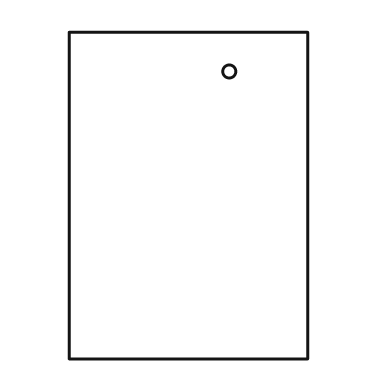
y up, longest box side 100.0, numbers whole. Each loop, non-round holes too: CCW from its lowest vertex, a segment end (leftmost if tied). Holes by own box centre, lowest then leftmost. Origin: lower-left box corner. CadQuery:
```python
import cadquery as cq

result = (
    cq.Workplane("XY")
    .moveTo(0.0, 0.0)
    .lineTo(73.0, 0.0)
    .lineTo(73.0, 100.0)
    .lineTo(0.0, 100.0)
    .close()
    .moveTo(49.0, 88.0)
    .circle(2.0)
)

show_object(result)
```